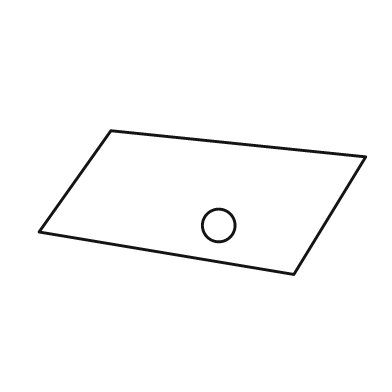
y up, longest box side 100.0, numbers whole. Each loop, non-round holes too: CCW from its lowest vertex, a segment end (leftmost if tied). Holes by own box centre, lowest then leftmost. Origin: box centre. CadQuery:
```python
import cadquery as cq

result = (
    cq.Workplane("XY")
    .moveTo(28.0, -22.0)
    .lineTo(50.0, 14.0)
    .lineTo(-28.0, 22.0)
    .lineTo(-50.0, -9.0)
    .close()
    .moveTo(5.0, -7.0)
    .circle(5.0)
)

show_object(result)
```